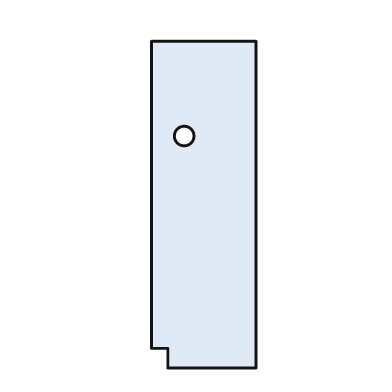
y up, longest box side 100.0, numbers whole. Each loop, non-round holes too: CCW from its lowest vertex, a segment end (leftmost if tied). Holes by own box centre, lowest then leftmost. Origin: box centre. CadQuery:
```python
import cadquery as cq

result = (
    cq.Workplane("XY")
    .moveTo(-11.0, -50.0)
    .lineTo(16.0, -50.0)
    .lineTo(16.0, 50.0)
    .lineTo(-16.0, 50.0)
    .lineTo(-16.0, -44.0)
    .lineTo(-11.0, -44.0)
    .close()
    .moveTo(-6.0, 21.0)
    .circle(3.0)
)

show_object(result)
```